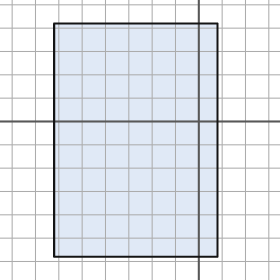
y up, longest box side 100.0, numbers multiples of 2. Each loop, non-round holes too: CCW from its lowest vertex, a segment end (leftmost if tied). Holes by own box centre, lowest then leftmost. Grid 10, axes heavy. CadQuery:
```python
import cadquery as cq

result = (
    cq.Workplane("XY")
    .moveTo(-62.0, -58.0)
    .lineTo(8.0, -58.0)
    .lineTo(8.0, 42.0)
    .lineTo(-62.0, 42.0)
    .close()
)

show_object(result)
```